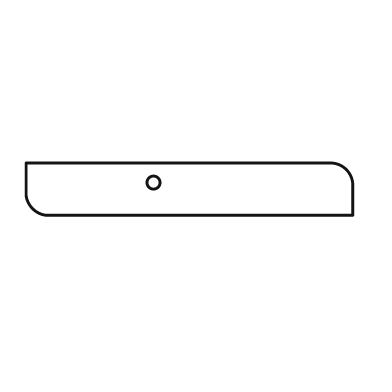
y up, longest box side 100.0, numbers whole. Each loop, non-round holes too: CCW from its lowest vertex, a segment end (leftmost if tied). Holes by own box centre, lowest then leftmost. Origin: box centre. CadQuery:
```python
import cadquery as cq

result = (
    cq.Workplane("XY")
    .moveTo(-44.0, -8.0)
    .lineTo(50.0, -8.0)
    .lineTo(50.0, 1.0)
    .threePointArc((48.0, 6.0), (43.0, 8.0))
    .lineTo(-50.0, 8.0)
    .lineTo(-50.0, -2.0)
    .threePointArc((-48.0, -6.0), (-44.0, -8.0))
    .close()
    .moveTo(-11.0, 2.0)
    .circle(2.0)
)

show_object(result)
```